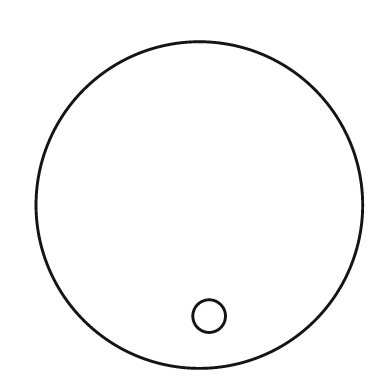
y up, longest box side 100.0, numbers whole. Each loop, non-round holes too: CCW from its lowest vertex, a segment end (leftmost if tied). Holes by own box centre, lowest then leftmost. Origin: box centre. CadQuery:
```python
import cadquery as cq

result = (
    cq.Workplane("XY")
    .moveTo(0.0, 0.0)
    .circle(50.0)
    .moveTo(3.0, -34.0)
    .circle(5.0)
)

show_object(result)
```